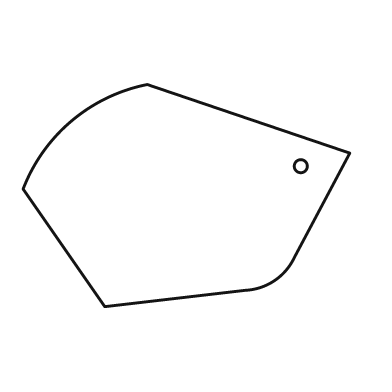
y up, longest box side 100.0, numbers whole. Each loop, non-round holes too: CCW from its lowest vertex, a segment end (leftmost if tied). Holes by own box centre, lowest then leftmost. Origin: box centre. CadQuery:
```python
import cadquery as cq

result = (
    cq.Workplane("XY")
    .moveTo(-25.0, -34.0)
    .lineTo(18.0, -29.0)
    .threePointArc((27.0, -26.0), (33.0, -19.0))
    .lineTo(50.0, 13.0)
    .lineTo(-12.0, 34.0)
    .threePointArc((-35.0, 23.0), (-50.0, 2.0))
    .close()
    .moveTo(35.0, 9.0)
    .circle(2.0)
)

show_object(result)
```